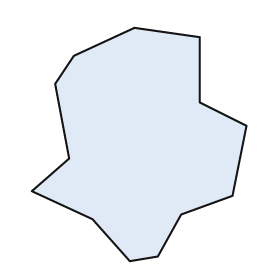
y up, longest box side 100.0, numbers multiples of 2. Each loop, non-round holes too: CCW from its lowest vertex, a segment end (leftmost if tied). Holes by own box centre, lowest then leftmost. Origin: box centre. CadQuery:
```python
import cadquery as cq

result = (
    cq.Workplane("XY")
    .moveTo(-4.0, -50.0)
    .lineTo(8.0, -48.0)
    .lineTo(18.0, -30.0)
    .lineTo(40.0, -22.0)
    .lineTo(46.0, 8.0)
    .lineTo(26.0, 18.0)
    .lineTo(26.0, 46.0)
    .lineTo(-2.0, 50.0)
    .lineTo(-28.0, 38.0)
    .lineTo(-36.0, 26.0)
    .lineTo(-30.0, -6.0)
    .lineTo(-46.0, -20.0)
    .lineTo(-20.0, -32.0)
    .close()
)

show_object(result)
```